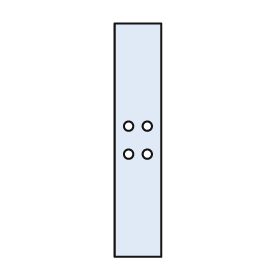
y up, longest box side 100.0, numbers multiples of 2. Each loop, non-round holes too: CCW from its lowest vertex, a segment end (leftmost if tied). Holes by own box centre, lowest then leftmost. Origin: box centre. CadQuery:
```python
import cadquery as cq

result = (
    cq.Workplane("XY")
    .moveTo(-10.0, -50.0)
    .lineTo(10.0, -50.0)
    .lineTo(10.0, 50.0)
    .lineTo(-10.0, 50.0)
    .close()
    .moveTo(-4.0, -6.0)
    .circle(2.0)
    .moveTo(4.0, -6.0)
    .circle(2.0)
    .moveTo(-4.0, 6.0)
    .circle(2.0)
    .moveTo(4.0, 6.0)
    .circle(2.0)
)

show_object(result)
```